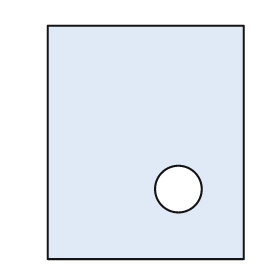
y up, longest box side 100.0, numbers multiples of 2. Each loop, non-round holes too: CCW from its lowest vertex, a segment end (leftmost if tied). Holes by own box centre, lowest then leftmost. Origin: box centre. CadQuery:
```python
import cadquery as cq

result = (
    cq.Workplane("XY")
    .moveTo(-42.0, -50.0)
    .lineTo(42.0, -50.0)
    .lineTo(42.0, 50.0)
    .lineTo(-42.0, 50.0)
    .close()
    .moveTo(14.0, -20.0)
    .circle(10.0)
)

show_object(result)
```